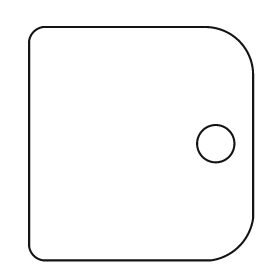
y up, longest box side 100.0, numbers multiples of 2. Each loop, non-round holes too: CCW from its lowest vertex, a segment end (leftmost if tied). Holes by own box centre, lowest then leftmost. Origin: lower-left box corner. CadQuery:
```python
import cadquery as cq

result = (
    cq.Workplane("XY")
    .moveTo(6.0, 0.0)
    .lineTo(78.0, 0.0)
    .threePointArc((90.0, 6.0), (96.0, 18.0))
    .lineTo(96.0, 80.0)
    .threePointArc((90.0, 94.0), (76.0, 100.0))
    .lineTo(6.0, 100.0)
    .threePointArc((2.0, 98.0), (0.0, 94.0))
    .lineTo(0.0, 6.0)
    .threePointArc((2.0, 2.0), (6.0, 0.0))
    .close()
    .moveTo(80.0, 50.0)
    .circle(8.0)
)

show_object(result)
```